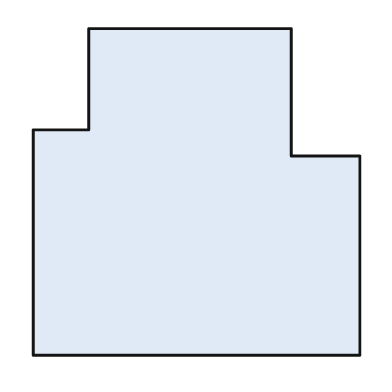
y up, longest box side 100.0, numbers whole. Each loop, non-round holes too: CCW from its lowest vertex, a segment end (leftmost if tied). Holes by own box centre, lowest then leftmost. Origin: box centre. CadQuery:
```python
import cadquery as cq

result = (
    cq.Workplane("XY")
    .moveTo(-50.0, -50.0)
    .lineTo(50.0, -50.0)
    .lineTo(50.0, 11.0)
    .lineTo(29.0, 11.0)
    .lineTo(29.0, 50.0)
    .lineTo(-33.0, 50.0)
    .lineTo(-33.0, 19.0)
    .lineTo(-50.0, 19.0)
    .close()
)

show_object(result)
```